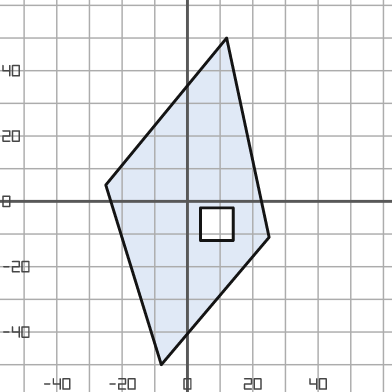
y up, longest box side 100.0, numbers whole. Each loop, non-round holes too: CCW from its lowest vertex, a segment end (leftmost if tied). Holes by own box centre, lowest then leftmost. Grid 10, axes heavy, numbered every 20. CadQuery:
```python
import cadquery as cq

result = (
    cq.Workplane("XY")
    .moveTo(-8.0, -50.0)
    .lineTo(25.0, -11.0)
    .lineTo(12.0, 50.0)
    .lineTo(-25.0, 5.0)
    .close()
    .moveTo(4.0, -12.0)
    .lineTo(14.0, -12.0)
    .lineTo(14.0, -2.0)
    .lineTo(4.0, -2.0)
    .close()
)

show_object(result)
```